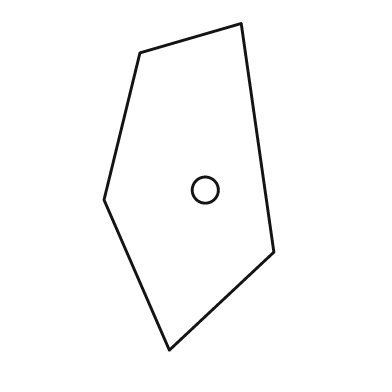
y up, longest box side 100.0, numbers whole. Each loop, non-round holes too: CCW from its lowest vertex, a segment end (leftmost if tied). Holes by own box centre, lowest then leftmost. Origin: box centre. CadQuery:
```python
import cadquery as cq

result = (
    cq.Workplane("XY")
    .moveTo(-6.0, -50.0)
    .lineTo(26.0, -20.0)
    .lineTo(16.0, 50.0)
    .lineTo(-15.0, 41.0)
    .lineTo(-26.0, -4.0)
    .close()
    .moveTo(5.0, -1.0)
    .circle(4.0)
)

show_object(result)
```